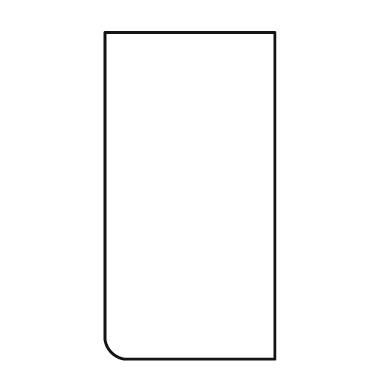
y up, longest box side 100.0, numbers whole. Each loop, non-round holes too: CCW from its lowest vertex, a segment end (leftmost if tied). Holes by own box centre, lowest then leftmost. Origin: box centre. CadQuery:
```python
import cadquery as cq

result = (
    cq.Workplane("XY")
    .moveTo(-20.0, -50.0)
    .lineTo(26.0, -50.0)
    .lineTo(26.0, 50.0)
    .lineTo(-26.0, 50.0)
    .lineTo(-26.0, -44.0)
    .threePointArc((-24.0, -48.0), (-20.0, -50.0))
    .close()
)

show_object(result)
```